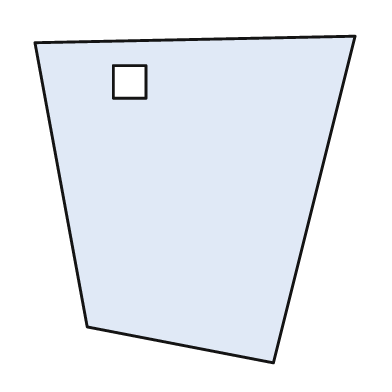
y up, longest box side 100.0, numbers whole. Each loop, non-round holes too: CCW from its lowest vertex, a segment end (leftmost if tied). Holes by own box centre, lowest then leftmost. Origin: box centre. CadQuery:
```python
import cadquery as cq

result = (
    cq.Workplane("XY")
    .moveTo(24.0, -50.0)
    .lineTo(49.0, 50.0)
    .lineTo(-49.0, 48.0)
    .lineTo(-33.0, -39.0)
    .close()
    .moveTo(-25.0, 31.0)
    .lineTo(-15.0, 31.0)
    .lineTo(-15.0, 41.0)
    .lineTo(-25.0, 41.0)
    .close()
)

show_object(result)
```